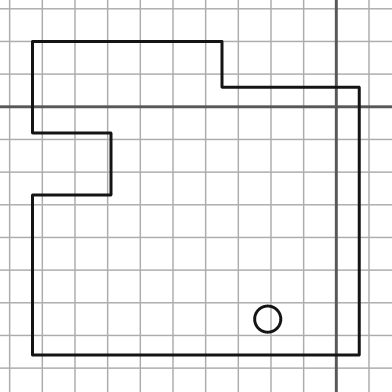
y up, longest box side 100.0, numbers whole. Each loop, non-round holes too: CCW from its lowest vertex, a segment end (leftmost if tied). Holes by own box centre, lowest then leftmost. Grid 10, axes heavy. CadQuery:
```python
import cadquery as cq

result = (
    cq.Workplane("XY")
    .moveTo(-93.0, -76.0)
    .lineTo(7.0, -76.0)
    .lineTo(7.0, 6.0)
    .lineTo(-35.0, 6.0)
    .lineTo(-35.0, 20.0)
    .lineTo(-93.0, 20.0)
    .lineTo(-93.0, -8.0)
    .lineTo(-69.0, -8.0)
    .lineTo(-69.0, -27.0)
    .lineTo(-93.0, -27.0)
    .close()
    .moveTo(-21.0, -65.0)
    .circle(4.0)
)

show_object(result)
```